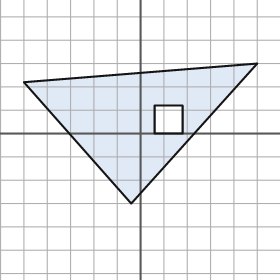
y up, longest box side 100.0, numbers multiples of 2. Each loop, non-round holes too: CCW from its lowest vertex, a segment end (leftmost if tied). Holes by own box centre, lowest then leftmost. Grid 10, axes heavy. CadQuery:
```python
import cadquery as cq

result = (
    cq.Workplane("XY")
    .moveTo(-4.0, -30.0)
    .lineTo(50.0, 30.0)
    .lineTo(-50.0, 22.0)
    .close()
    .moveTo(6.0, 0.0)
    .lineTo(18.0, 0.0)
    .lineTo(18.0, 12.0)
    .lineTo(6.0, 12.0)
    .close()
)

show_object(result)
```